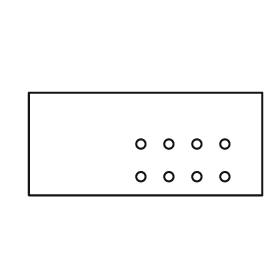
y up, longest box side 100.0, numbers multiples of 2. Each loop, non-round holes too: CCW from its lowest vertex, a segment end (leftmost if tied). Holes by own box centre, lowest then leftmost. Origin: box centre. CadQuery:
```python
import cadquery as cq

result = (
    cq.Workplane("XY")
    .moveTo(-50.0, -22.0)
    .lineTo(50.0, -22.0)
    .lineTo(50.0, 22.0)
    .lineTo(-50.0, 22.0)
    .close()
    .moveTo(-2.0, -14.0)
    .circle(2.0)
    .moveTo(10.0, -14.0)
    .circle(2.0)
    .moveTo(22.0, -14.0)
    .circle(2.0)
    .moveTo(34.0, -14.0)
    .circle(2.0)
    .moveTo(-2.0, 0.0)
    .circle(2.0)
    .moveTo(10.0, 0.0)
    .circle(2.0)
    .moveTo(22.0, 0.0)
    .circle(2.0)
    .moveTo(34.0, 0.0)
    .circle(2.0)
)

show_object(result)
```